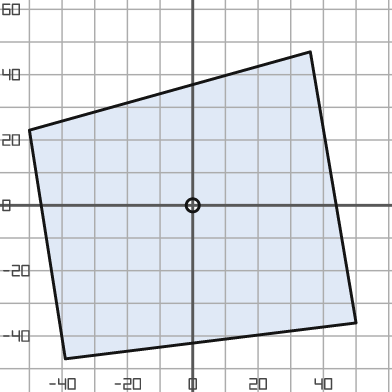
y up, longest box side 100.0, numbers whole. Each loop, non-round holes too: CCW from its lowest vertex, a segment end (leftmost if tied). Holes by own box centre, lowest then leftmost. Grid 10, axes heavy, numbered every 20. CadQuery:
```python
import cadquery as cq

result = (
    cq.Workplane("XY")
    .moveTo(-39.0, -47.0)
    .lineTo(50.0, -36.0)
    .lineTo(36.0, 47.0)
    .lineTo(-50.0, 23.0)
    .close()
    .moveTo(0.0, 0.0)
    .circle(2.0)
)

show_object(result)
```